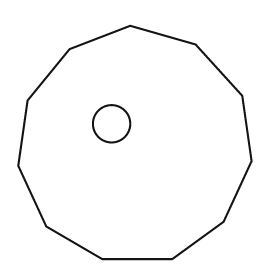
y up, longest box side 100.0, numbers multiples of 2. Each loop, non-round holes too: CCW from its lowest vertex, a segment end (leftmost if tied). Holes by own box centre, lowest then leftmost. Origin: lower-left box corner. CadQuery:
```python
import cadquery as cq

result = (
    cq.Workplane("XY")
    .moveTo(36.0, 0.0)
    .lineTo(66.0, 0.0)
    .lineTo(88.0, 16.0)
    .lineTo(100.0, 42.0)
    .lineTo(96.0, 70.0)
    .lineTo(76.0, 92.0)
    .lineTo(48.0, 100.0)
    .lineTo(22.0, 90.0)
    .lineTo(4.0, 68.0)
    .lineTo(0.0, 40.0)
    .lineTo(12.0, 14.0)
    .close()
    .moveTo(40.0, 58.0)
    .circle(8.0)
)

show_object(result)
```